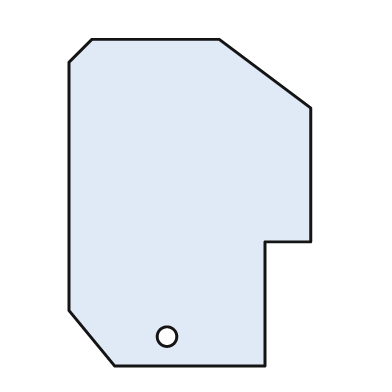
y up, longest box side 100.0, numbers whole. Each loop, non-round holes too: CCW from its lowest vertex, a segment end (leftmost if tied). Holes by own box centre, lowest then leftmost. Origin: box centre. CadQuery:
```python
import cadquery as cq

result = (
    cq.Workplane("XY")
    .moveTo(-23.0, -50.0)
    .lineTo(23.0, -50.0)
    .lineTo(23.0, -12.0)
    .lineTo(37.0, -12.0)
    .lineTo(37.0, 29.0)
    .lineTo(9.0, 50.0)
    .lineTo(-30.0, 50.0)
    .lineTo(-37.0, 43.0)
    .lineTo(-37.0, -33.0)
    .close()
    .moveTo(-7.0, -41.0)
    .circle(3.0)
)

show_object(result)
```